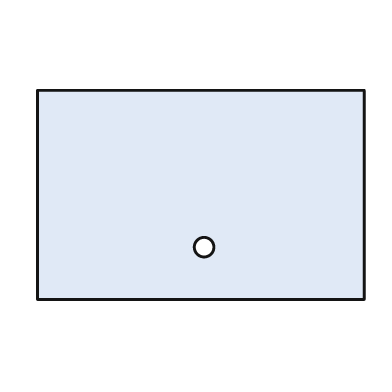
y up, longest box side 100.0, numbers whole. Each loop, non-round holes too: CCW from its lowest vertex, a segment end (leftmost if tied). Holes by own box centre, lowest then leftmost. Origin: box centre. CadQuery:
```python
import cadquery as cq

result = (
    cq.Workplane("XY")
    .moveTo(-50.0, -32.0)
    .lineTo(50.0, -32.0)
    .lineTo(50.0, 32.0)
    .lineTo(-50.0, 32.0)
    .close()
    .moveTo(1.0, -16.0)
    .circle(3.0)
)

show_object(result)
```